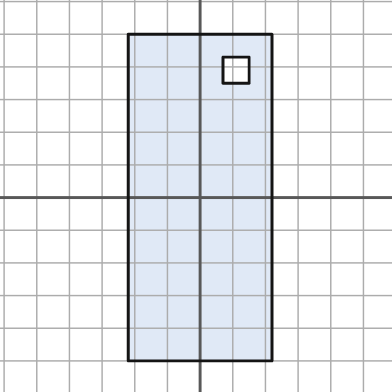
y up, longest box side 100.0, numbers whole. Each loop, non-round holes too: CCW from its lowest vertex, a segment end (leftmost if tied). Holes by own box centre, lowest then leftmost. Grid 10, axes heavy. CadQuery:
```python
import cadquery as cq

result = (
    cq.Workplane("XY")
    .moveTo(-22.0, -50.0)
    .lineTo(22.0, -50.0)
    .lineTo(22.0, 50.0)
    .lineTo(-22.0, 50.0)
    .close()
    .moveTo(7.0, 35.0)
    .lineTo(15.0, 35.0)
    .lineTo(15.0, 43.0)
    .lineTo(7.0, 43.0)
    .close()
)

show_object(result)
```